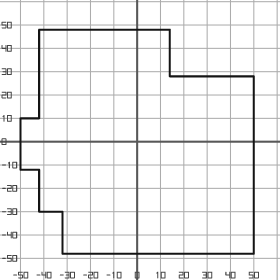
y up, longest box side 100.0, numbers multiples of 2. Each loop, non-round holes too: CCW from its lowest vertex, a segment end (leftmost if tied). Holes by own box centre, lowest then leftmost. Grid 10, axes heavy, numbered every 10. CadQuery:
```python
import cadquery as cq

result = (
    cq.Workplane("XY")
    .moveTo(-32.0, -48.0)
    .lineTo(50.0, -48.0)
    .lineTo(50.0, 28.0)
    .lineTo(14.0, 28.0)
    .lineTo(14.0, 48.0)
    .lineTo(-42.0, 48.0)
    .lineTo(-42.0, 10.0)
    .lineTo(-50.0, 10.0)
    .lineTo(-50.0, -12.0)
    .lineTo(-42.0, -12.0)
    .lineTo(-42.0, -30.0)
    .lineTo(-32.0, -30.0)
    .close()
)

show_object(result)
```